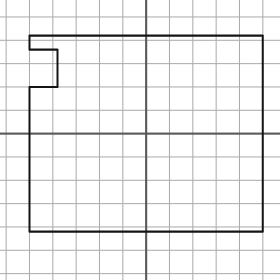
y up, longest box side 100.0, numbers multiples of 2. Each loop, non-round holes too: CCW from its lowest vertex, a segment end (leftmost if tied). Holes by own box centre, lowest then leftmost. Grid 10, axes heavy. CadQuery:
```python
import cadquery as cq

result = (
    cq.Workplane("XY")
    .moveTo(-50.0, -42.0)
    .lineTo(50.0, -42.0)
    .lineTo(50.0, 42.0)
    .lineTo(-50.0, 42.0)
    .lineTo(-50.0, 36.0)
    .lineTo(-38.0, 36.0)
    .lineTo(-38.0, 20.0)
    .lineTo(-50.0, 20.0)
    .close()
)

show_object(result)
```